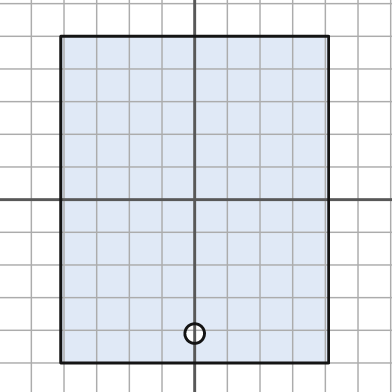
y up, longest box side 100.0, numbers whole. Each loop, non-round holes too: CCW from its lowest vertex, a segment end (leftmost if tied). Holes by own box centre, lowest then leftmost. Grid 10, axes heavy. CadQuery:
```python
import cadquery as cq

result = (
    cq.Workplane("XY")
    .moveTo(-41.0, -50.0)
    .lineTo(41.0, -50.0)
    .lineTo(41.0, 50.0)
    .lineTo(-41.0, 50.0)
    .close()
    .moveTo(0.0, -41.0)
    .circle(3.0)
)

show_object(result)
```